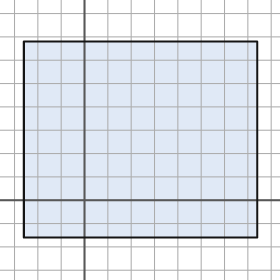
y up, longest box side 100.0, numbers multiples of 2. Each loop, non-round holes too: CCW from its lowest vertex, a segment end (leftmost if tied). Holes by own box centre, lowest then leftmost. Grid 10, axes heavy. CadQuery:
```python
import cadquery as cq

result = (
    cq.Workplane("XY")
    .moveTo(-26.0, -16.0)
    .lineTo(74.0, -16.0)
    .lineTo(74.0, 68.0)
    .lineTo(-26.0, 68.0)
    .close()
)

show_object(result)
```